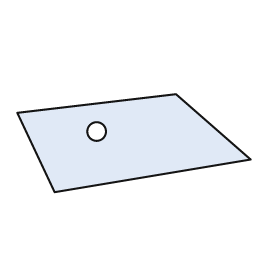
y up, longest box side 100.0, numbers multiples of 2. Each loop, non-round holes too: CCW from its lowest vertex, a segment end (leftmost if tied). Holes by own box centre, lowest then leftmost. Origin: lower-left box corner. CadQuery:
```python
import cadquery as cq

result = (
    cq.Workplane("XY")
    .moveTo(16.0, 0.0)
    .lineTo(100.0, 14.0)
    .lineTo(68.0, 42.0)
    .lineTo(0.0, 34.0)
    .close()
    .moveTo(34.0, 26.0)
    .circle(4.0)
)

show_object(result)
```